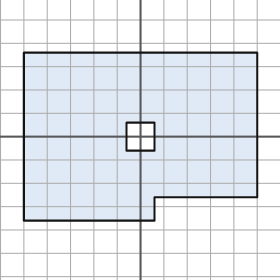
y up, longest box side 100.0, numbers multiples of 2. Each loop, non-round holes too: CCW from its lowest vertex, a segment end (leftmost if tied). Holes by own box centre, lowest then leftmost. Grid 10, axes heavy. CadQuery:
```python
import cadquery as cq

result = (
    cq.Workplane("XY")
    .moveTo(-50.0, -36.0)
    .lineTo(6.0, -36.0)
    .lineTo(6.0, -26.0)
    .lineTo(50.0, -26.0)
    .lineTo(50.0, 36.0)
    .lineTo(-50.0, 36.0)
    .close()
    .moveTo(-6.0, -6.0)
    .lineTo(6.0, -6.0)
    .lineTo(6.0, 6.0)
    .lineTo(-6.0, 6.0)
    .close()
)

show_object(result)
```